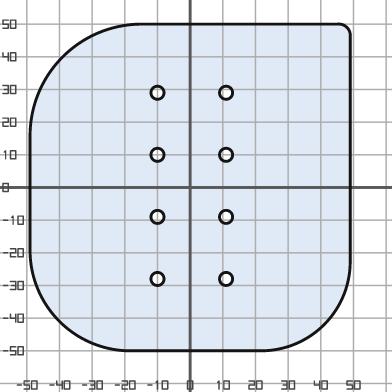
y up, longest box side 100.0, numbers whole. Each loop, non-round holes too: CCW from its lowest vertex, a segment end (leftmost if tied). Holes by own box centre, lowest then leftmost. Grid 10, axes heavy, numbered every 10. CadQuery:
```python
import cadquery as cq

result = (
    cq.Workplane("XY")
    .moveTo(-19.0, -50.0)
    .lineTo(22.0, -50.0)
    .threePointArc((41.0, -42.0), (49.0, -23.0))
    .lineTo(49.0, 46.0)
    .threePointArc((48.0, 49.0), (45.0, 50.0))
    .lineTo(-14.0, 50.0)
    .threePointArc((-39.0, 40.0), (-49.0, 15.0))
    .lineTo(-49.0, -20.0)
    .threePointArc((-40.0, -41.0), (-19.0, -50.0))
    .close()
    .moveTo(-10.0, -28.0)
    .circle(2.0)
    .moveTo(11.0, -28.0)
    .circle(2.0)
    .moveTo(-10.0, -9.0)
    .circle(2.0)
    .moveTo(11.0, -9.0)
    .circle(2.0)
    .moveTo(-10.0, 10.0)
    .circle(2.0)
    .moveTo(11.0, 10.0)
    .circle(2.0)
    .moveTo(-10.0, 29.0)
    .circle(2.0)
    .moveTo(11.0, 29.0)
    .circle(2.0)
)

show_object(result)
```